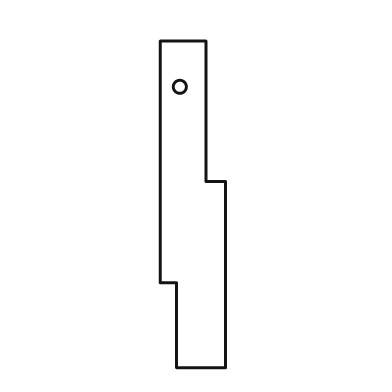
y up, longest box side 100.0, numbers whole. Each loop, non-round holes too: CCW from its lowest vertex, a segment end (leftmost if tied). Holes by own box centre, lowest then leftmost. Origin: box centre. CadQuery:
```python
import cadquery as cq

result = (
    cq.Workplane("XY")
    .moveTo(-5.0, -50.0)
    .lineTo(10.0, -50.0)
    .lineTo(10.0, 7.0)
    .lineTo(4.0, 7.0)
    .lineTo(4.0, 50.0)
    .lineTo(-10.0, 50.0)
    .lineTo(-10.0, -24.0)
    .lineTo(-5.0, -24.0)
    .close()
    .moveTo(-4.0, 36.0)
    .circle(2.0)
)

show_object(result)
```